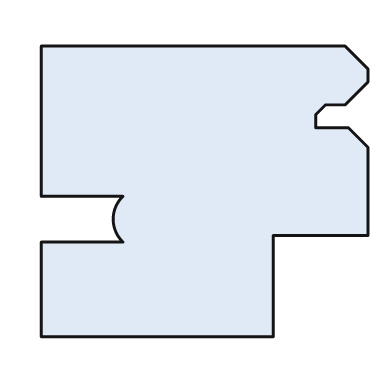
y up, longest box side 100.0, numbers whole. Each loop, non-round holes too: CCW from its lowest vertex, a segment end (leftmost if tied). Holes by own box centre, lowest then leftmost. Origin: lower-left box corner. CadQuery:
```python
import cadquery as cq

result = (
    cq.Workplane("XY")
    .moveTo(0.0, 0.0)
    .lineTo(71.0, 0.0)
    .lineTo(71.0, 31.0)
    .lineTo(100.0, 31.0)
    .lineTo(100.0, 58.0)
    .lineTo(94.0, 64.0)
    .lineTo(84.0, 64.0)
    .lineTo(84.0, 68.0)
    .lineTo(87.0, 71.0)
    .lineTo(93.0, 71.0)
    .lineTo(100.0, 78.0)
    .lineTo(100.0, 82.0)
    .lineTo(93.0, 89.0)
    .lineTo(0.0, 89.0)
    .lineTo(0.0, 43.0)
    .lineTo(25.0, 43.0)
    .threePointArc((22.0, 36.0), (25.0, 29.0))
    .lineTo(0.0, 29.0)
    .close()
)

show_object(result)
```